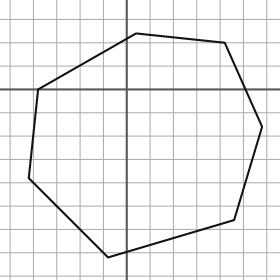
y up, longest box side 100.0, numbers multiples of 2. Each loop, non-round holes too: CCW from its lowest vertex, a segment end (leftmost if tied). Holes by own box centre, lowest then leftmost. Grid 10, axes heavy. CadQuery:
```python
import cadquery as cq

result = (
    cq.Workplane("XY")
    .moveTo(-8.0, -72.0)
    .lineTo(46.0, -56.0)
    .lineTo(58.0, -16.0)
    .lineTo(42.0, 20.0)
    .lineTo(4.0, 24.0)
    .lineTo(-38.0, 0.0)
    .lineTo(-42.0, -38.0)
    .close()
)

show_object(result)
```